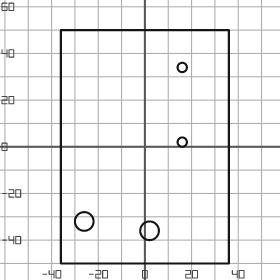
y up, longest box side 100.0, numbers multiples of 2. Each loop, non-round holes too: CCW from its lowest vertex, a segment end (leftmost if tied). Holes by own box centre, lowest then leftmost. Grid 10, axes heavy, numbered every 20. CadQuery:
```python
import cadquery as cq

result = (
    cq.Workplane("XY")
    .moveTo(-36.0, -50.0)
    .lineTo(36.0, -50.0)
    .lineTo(36.0, 50.0)
    .lineTo(-36.0, 50.0)
    .close()
    .moveTo(2.0, -36.0)
    .circle(4.0)
    .moveTo(-26.0, -32.0)
    .circle(4.0)
    .moveTo(16.0, 2.0)
    .circle(2.0)
    .moveTo(16.0, 34.0)
    .circle(2.0)
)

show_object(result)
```